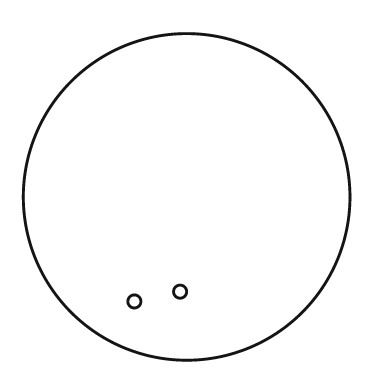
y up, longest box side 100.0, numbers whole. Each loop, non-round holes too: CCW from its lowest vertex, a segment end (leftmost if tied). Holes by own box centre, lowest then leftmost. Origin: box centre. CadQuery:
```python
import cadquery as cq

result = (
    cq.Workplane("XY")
    .moveTo(0.0, 0.0)
    .circle(50.0)
    .moveTo(-16.0, -32.0)
    .circle(2.0)
    .moveTo(-2.0, -29.0)
    .circle(2.0)
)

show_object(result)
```